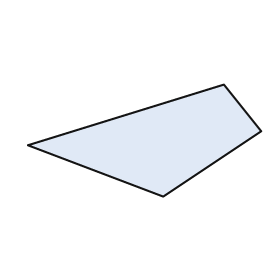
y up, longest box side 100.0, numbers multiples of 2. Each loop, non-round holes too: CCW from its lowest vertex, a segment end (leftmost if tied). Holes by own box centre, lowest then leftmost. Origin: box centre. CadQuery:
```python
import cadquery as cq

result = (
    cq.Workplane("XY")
    .moveTo(8.0, -24.0)
    .lineTo(50.0, 4.0)
    .lineTo(34.0, 24.0)
    .lineTo(-50.0, -2.0)
    .close()
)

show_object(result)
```